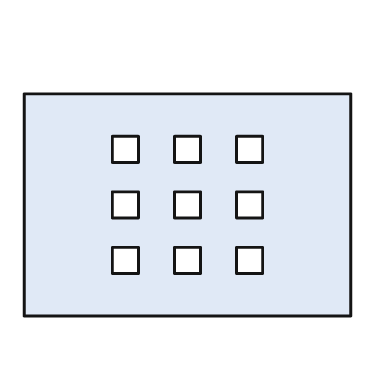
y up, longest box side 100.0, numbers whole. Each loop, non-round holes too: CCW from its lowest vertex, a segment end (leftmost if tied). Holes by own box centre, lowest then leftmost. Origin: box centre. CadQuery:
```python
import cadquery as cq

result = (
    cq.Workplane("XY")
    .moveTo(-50.0, -34.0)
    .lineTo(50.0, -34.0)
    .lineTo(50.0, 34.0)
    .lineTo(-50.0, 34.0)
    .close()
    .moveTo(-23.0, -21.0)
    .lineTo(-15.0, -21.0)
    .lineTo(-15.0, -13.0)
    .lineTo(-23.0, -13.0)
    .close()
    .moveTo(-4.0, -21.0)
    .lineTo(4.0, -21.0)
    .lineTo(4.0, -13.0)
    .lineTo(-4.0, -13.0)
    .close()
    .moveTo(15.0, -21.0)
    .lineTo(23.0, -21.0)
    .lineTo(23.0, -13.0)
    .lineTo(15.0, -13.0)
    .close()
    .moveTo(-23.0, -4.0)
    .lineTo(-15.0, -4.0)
    .lineTo(-15.0, 4.0)
    .lineTo(-23.0, 4.0)
    .close()
    .moveTo(-4.0, -4.0)
    .lineTo(4.0, -4.0)
    .lineTo(4.0, 4.0)
    .lineTo(-4.0, 4.0)
    .close()
    .moveTo(15.0, -4.0)
    .lineTo(23.0, -4.0)
    .lineTo(23.0, 4.0)
    .lineTo(15.0, 4.0)
    .close()
    .moveTo(-23.0, 13.0)
    .lineTo(-15.0, 13.0)
    .lineTo(-15.0, 21.0)
    .lineTo(-23.0, 21.0)
    .close()
    .moveTo(-4.0, 13.0)
    .lineTo(4.0, 13.0)
    .lineTo(4.0, 21.0)
    .lineTo(-4.0, 21.0)
    .close()
    .moveTo(15.0, 13.0)
    .lineTo(23.0, 13.0)
    .lineTo(23.0, 21.0)
    .lineTo(15.0, 21.0)
    .close()
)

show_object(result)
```